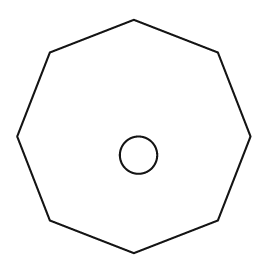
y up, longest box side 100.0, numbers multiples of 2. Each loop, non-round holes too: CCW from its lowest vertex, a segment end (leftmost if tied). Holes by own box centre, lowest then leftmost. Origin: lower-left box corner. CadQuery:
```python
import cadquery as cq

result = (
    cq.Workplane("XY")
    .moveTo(50.0, 0.0)
    .lineTo(86.0, 14.0)
    .lineTo(100.0, 50.0)
    .lineTo(86.0, 86.0)
    .lineTo(50.0, 100.0)
    .lineTo(14.0, 86.0)
    .lineTo(0.0, 50.0)
    .lineTo(14.0, 14.0)
    .close()
    .moveTo(52.0, 42.0)
    .circle(8.0)
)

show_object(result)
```